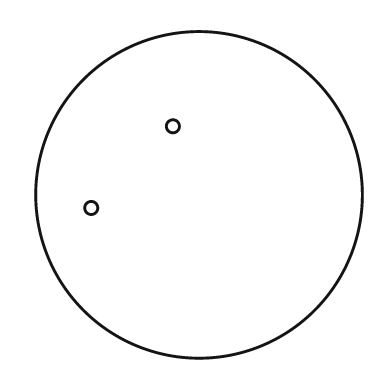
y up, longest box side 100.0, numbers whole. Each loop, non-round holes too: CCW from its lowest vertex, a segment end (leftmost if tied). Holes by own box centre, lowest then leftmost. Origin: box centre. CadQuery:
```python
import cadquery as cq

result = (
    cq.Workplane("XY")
    .moveTo(0.0, 0.0)
    .circle(50.0)
    .moveTo(-33.0, -4.0)
    .circle(2.0)
    .moveTo(-8.0, 21.0)
    .circle(2.0)
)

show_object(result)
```